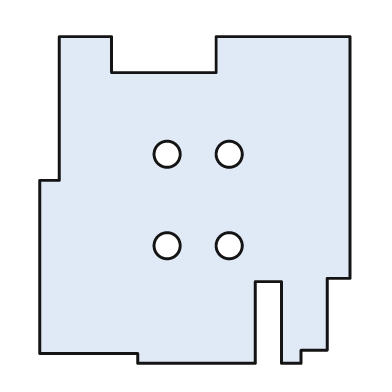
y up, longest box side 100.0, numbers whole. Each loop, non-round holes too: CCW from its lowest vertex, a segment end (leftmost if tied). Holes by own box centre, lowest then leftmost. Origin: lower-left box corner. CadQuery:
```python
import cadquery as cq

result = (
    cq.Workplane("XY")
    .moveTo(30.0, 0.0)
    .lineTo(66.0, 0.0)
    .lineTo(66.0, 25.0)
    .lineTo(74.0, 25.0)
    .lineTo(74.0, 0.0)
    .lineTo(80.0, 0.0)
    .lineTo(80.0, 4.0)
    .lineTo(88.0, 4.0)
    .lineTo(88.0, 26.0)
    .lineTo(95.0, 26.0)
    .lineTo(95.0, 100.0)
    .lineTo(54.0, 100.0)
    .lineTo(54.0, 89.0)
    .lineTo(22.0, 89.0)
    .lineTo(22.0, 100.0)
    .lineTo(6.0, 100.0)
    .lineTo(6.0, 56.0)
    .lineTo(0.0, 56.0)
    .lineTo(0.0, 3.0)
    .lineTo(30.0, 3.0)
    .close()
    .moveTo(39.0, 36.0)
    .circle(4.0)
    .moveTo(58.0, 36.0)
    .circle(4.0)
    .moveTo(39.0, 64.0)
    .circle(4.0)
    .moveTo(58.0, 64.0)
    .circle(4.0)
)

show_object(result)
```